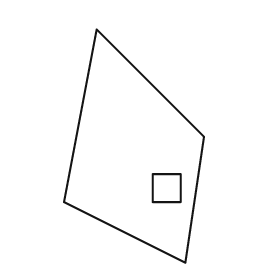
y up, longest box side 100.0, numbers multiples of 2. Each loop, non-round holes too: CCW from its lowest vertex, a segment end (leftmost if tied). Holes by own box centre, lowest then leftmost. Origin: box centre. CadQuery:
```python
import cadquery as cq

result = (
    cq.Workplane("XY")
    .moveTo(22.0, -50.0)
    .lineTo(30.0, 4.0)
    .lineTo(-16.0, 50.0)
    .lineTo(-30.0, -24.0)
    .close()
    .moveTo(8.0, -24.0)
    .lineTo(20.0, -24.0)
    .lineTo(20.0, -12.0)
    .lineTo(8.0, -12.0)
    .close()
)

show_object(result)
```